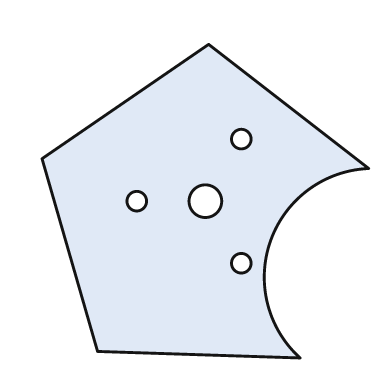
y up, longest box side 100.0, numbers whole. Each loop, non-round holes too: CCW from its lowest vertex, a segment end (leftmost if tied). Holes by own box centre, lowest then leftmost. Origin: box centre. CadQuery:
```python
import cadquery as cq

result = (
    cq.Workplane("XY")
    .moveTo(29.0, -48.0)
    .threePointArc((20.0, -12.0), (50.0, 10.0))
    .lineTo(1.0, 48.0)
    .lineTo(-50.0, 13.0)
    .lineTo(-33.0, -46.0)
    .close()
    .moveTo(11.0, -19.0)
    .circle(3.0)
    .moveTo(-21.0, 0.0)
    .circle(3.0)
    .moveTo(0.0, 0.0)
    .circle(5.0)
    .moveTo(11.0, 19.0)
    .circle(3.0)
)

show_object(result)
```